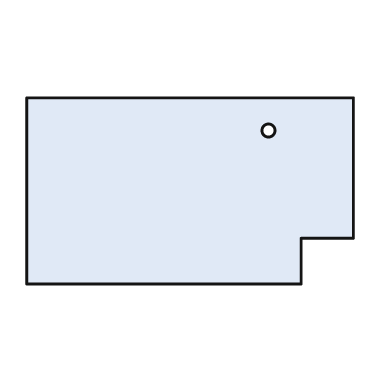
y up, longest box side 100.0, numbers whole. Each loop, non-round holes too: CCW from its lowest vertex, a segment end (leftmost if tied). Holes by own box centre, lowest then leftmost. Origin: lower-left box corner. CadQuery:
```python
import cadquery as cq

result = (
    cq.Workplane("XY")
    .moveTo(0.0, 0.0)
    .lineTo(84.0, 0.0)
    .lineTo(84.0, 14.0)
    .lineTo(100.0, 14.0)
    .lineTo(100.0, 57.0)
    .lineTo(0.0, 57.0)
    .close()
    .moveTo(74.0, 47.0)
    .circle(2.0)
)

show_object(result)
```